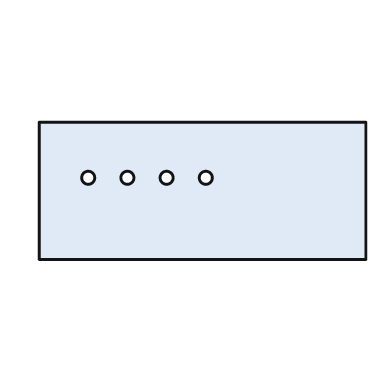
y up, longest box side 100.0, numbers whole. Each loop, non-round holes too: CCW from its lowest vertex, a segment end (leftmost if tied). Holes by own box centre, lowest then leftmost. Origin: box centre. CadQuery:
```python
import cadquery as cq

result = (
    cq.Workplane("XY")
    .moveTo(-50.0, -21.0)
    .lineTo(50.0, -21.0)
    .lineTo(50.0, 21.0)
    .lineTo(-50.0, 21.0)
    .close()
    .moveTo(-35.0, 4.0)
    .circle(2.0)
    .moveTo(-23.0, 4.0)
    .circle(2.0)
    .moveTo(-11.0, 4.0)
    .circle(2.0)
    .moveTo(1.0, 4.0)
    .circle(2.0)
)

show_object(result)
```